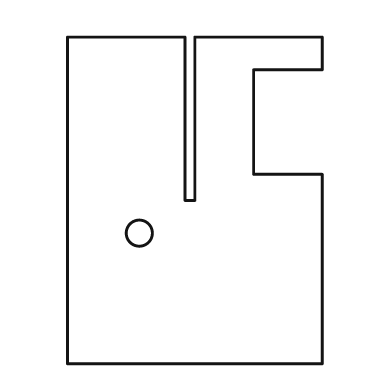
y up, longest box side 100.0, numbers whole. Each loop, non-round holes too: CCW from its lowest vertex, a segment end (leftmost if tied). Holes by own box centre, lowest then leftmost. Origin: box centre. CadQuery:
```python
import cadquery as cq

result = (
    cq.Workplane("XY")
    .moveTo(-39.0, -50.0)
    .lineTo(39.0, -50.0)
    .lineTo(39.0, 8.0)
    .lineTo(18.0, 8.0)
    .lineTo(18.0, 40.0)
    .lineTo(39.0, 40.0)
    .lineTo(39.0, 50.0)
    .lineTo(0.0, 50.0)
    .lineTo(0.0, 0.0)
    .lineTo(-3.0, 0.0)
    .lineTo(-3.0, 50.0)
    .lineTo(-39.0, 50.0)
    .close()
    .moveTo(-17.0, -10.0)
    .circle(4.0)
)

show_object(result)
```